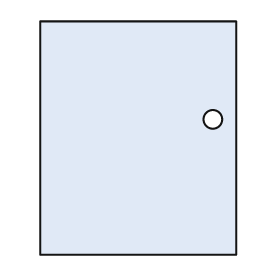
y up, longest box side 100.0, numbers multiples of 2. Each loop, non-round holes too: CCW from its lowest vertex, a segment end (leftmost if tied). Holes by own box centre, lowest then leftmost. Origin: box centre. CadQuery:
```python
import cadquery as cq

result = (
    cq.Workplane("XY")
    .moveTo(-42.0, -50.0)
    .lineTo(42.0, -50.0)
    .lineTo(42.0, 50.0)
    .lineTo(-42.0, 50.0)
    .close()
    .moveTo(32.0, 8.0)
    .circle(4.0)
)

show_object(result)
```